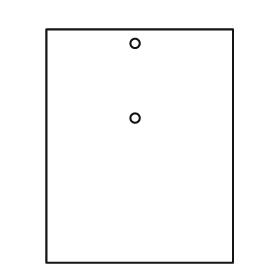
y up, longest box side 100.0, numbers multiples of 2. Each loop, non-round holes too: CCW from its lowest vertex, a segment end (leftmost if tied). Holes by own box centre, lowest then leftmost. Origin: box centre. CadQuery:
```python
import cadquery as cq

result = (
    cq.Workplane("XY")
    .moveTo(-40.0, -50.0)
    .lineTo(40.0, -50.0)
    .lineTo(40.0, 50.0)
    .lineTo(-40.0, 50.0)
    .close()
    .moveTo(-2.0, 12.0)
    .circle(2.0)
    .moveTo(-2.0, 44.0)
    .circle(2.0)
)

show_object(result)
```